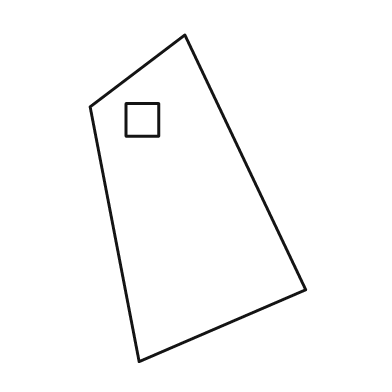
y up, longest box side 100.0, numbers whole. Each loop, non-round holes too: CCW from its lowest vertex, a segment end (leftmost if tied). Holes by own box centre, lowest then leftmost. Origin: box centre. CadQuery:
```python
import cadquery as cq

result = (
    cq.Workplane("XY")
    .moveTo(-18.0, -50.0)
    .lineTo(33.0, -28.0)
    .lineTo(-4.0, 50.0)
    .lineTo(-33.0, 28.0)
    .close()
    .moveTo(-22.0, 19.0)
    .lineTo(-12.0, 19.0)
    .lineTo(-12.0, 29.0)
    .lineTo(-22.0, 29.0)
    .close()
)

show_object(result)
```